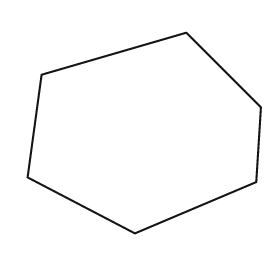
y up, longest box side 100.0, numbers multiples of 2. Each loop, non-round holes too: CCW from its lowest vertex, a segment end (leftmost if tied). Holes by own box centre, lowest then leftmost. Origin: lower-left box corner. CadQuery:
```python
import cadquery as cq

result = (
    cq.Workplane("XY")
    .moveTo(46.0, 0.0)
    .lineTo(98.0, 22.0)
    .lineTo(100.0, 54.0)
    .lineTo(68.0, 86.0)
    .lineTo(6.0, 68.0)
    .lineTo(0.0, 24.0)
    .close()
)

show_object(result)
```